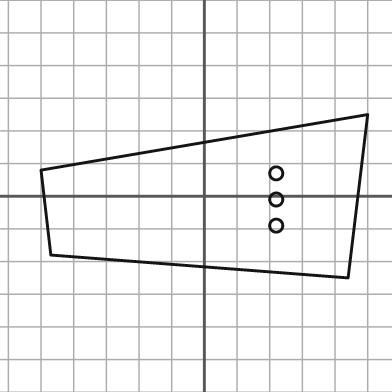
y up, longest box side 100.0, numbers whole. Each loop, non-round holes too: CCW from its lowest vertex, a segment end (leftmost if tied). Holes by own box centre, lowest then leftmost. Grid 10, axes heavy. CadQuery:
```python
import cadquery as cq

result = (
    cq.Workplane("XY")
    .moveTo(44.0, -25.0)
    .lineTo(50.0, 25.0)
    .lineTo(-50.0, 8.0)
    .lineTo(-47.0, -18.0)
    .close()
    .moveTo(22.0, -9.0)
    .circle(2.0)
    .moveTo(22.0, -1.0)
    .circle(2.0)
    .moveTo(22.0, 7.0)
    .circle(2.0)
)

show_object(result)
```